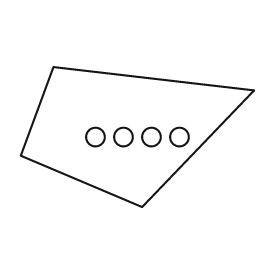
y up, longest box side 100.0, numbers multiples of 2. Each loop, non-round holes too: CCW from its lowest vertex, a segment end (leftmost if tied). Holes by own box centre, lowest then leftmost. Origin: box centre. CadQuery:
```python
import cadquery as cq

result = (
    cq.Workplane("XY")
    .moveTo(2.0, -30.0)
    .lineTo(50.0, 20.0)
    .lineTo(-36.0, 30.0)
    .lineTo(-50.0, -8.0)
    .close()
    .moveTo(-18.0, 0.0)
    .circle(4.0)
    .moveTo(-6.0, 0.0)
    .circle(4.0)
    .moveTo(6.0, 0.0)
    .circle(4.0)
    .moveTo(18.0, 0.0)
    .circle(4.0)
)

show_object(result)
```